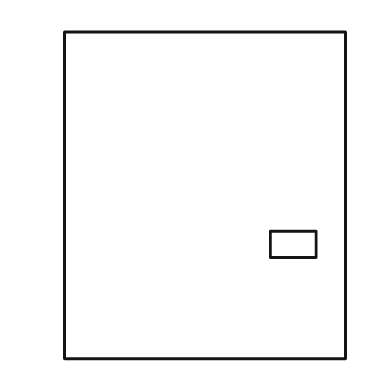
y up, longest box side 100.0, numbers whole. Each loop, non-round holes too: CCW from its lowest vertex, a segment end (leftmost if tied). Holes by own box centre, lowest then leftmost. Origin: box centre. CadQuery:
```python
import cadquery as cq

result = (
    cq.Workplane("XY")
    .moveTo(-43.0, -50.0)
    .lineTo(43.0, -50.0)
    .lineTo(43.0, 50.0)
    .lineTo(-43.0, 50.0)
    .close()
    .moveTo(20.0, -19.0)
    .lineTo(34.0, -19.0)
    .lineTo(34.0, -11.0)
    .lineTo(20.0, -11.0)
    .close()
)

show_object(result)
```